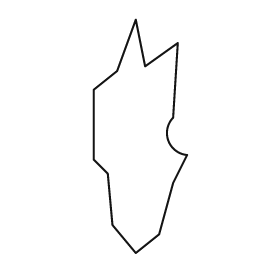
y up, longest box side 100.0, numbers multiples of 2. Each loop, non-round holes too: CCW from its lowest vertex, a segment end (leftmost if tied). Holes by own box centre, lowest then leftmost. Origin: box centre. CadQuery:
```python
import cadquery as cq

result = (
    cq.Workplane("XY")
    .moveTo(-2.0, -50.0)
    .lineTo(8.0, -42.0)
    .lineTo(14.0, -20.0)
    .lineTo(20.0, -8.0)
    .threePointArc((12.0, -2.0), (14.0, 8.0))
    .lineTo(16.0, 40.0)
    .lineTo(2.0, 30.0)
    .lineTo(-2.0, 50.0)
    .lineTo(-10.0, 28.0)
    .lineTo(-20.0, 20.0)
    .lineTo(-20.0, -10.0)
    .lineTo(-14.0, -16.0)
    .lineTo(-12.0, -38.0)
    .close()
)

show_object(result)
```